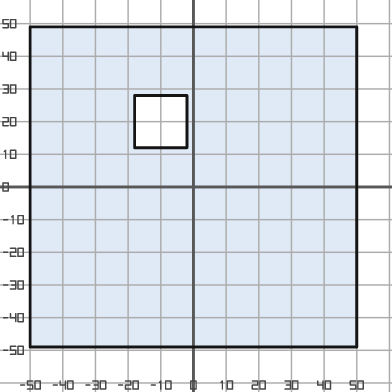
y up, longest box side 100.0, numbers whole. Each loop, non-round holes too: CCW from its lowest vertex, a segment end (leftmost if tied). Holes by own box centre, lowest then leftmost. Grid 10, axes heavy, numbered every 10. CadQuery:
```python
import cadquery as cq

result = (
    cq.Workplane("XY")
    .moveTo(-50.0, -49.0)
    .lineTo(50.0, -49.0)
    .lineTo(50.0, 49.0)
    .lineTo(-50.0, 49.0)
    .close()
    .moveTo(-18.0, 12.0)
    .lineTo(-2.0, 12.0)
    .lineTo(-2.0, 28.0)
    .lineTo(-18.0, 28.0)
    .close()
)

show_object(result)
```